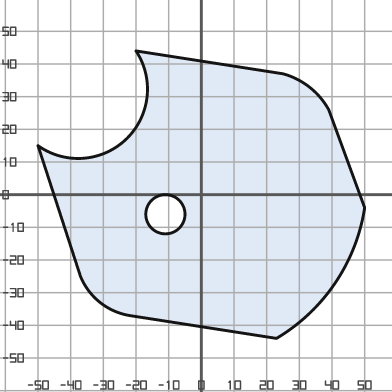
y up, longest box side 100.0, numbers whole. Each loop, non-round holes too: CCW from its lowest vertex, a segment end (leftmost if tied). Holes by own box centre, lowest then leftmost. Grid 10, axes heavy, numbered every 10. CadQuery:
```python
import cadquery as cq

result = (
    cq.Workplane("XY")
    .moveTo(23.0, -44.0)
    .threePointArc((41.0, -27.0), (50.0, -4.0))
    .lineTo(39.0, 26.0)
    .threePointArc((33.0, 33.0), (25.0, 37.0))
    .lineTo(-20.0, 44.0)
    .threePointArc((-23.0, 17.0), (-50.0, 15.0))
    .lineTo(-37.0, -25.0)
    .threePointArc((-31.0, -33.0), (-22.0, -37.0))
    .close()
    .moveTo(-11.0, -6.0)
    .circle(6.0)
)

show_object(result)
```